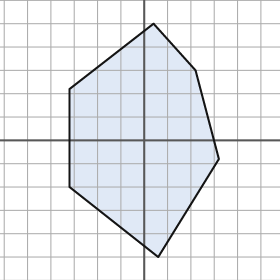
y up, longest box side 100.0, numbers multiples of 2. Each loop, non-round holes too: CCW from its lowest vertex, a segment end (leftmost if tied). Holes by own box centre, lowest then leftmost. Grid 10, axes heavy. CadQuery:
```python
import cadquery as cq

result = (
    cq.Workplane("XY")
    .moveTo(6.0, -50.0)
    .lineTo(32.0, -8.0)
    .lineTo(22.0, 30.0)
    .lineTo(4.0, 50.0)
    .lineTo(-32.0, 22.0)
    .lineTo(-32.0, -20.0)
    .close()
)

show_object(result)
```